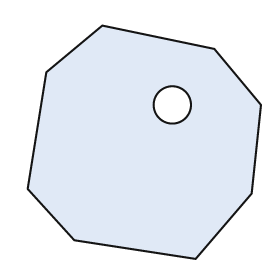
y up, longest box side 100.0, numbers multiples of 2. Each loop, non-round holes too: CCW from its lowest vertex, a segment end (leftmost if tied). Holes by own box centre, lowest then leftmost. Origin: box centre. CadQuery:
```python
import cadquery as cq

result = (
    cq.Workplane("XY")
    .moveTo(22.0, -50.0)
    .lineTo(46.0, -22.0)
    .lineTo(50.0, 16.0)
    .lineTo(30.0, 40.0)
    .lineTo(-18.0, 50.0)
    .lineTo(-42.0, 30.0)
    .lineTo(-50.0, -20.0)
    .lineTo(-30.0, -42.0)
    .close()
    .moveTo(12.0, 16.0)
    .circle(8.0)
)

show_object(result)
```